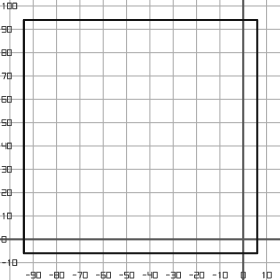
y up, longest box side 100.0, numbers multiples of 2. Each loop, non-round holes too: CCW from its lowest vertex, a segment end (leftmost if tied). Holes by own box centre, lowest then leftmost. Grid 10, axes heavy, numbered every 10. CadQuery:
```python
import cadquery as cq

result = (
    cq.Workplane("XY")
    .moveTo(-94.0, -6.0)
    .lineTo(6.0, -6.0)
    .lineTo(6.0, 94.0)
    .lineTo(-94.0, 94.0)
    .close()
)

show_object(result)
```